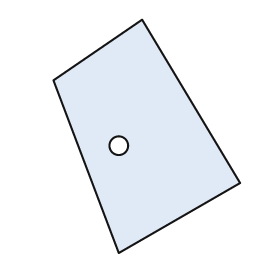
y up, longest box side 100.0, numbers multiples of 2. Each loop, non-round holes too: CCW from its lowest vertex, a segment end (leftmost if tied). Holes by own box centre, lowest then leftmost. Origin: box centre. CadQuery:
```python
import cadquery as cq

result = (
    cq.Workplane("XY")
    .moveTo(-12.0, -50.0)
    .lineTo(40.0, -20.0)
    .lineTo(-2.0, 50.0)
    .lineTo(-40.0, 24.0)
    .close()
    .moveTo(-12.0, -4.0)
    .circle(4.0)
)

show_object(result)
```